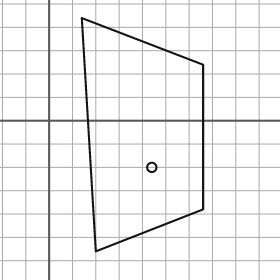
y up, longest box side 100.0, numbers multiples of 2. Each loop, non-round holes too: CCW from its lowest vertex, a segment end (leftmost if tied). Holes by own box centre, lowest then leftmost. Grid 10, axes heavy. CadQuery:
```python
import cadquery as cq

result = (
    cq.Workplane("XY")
    .moveTo(20.0, -56.0)
    .lineTo(66.0, -38.0)
    .lineTo(66.0, 24.0)
    .lineTo(14.0, 44.0)
    .close()
    .moveTo(44.0, -20.0)
    .circle(2.0)
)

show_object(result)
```